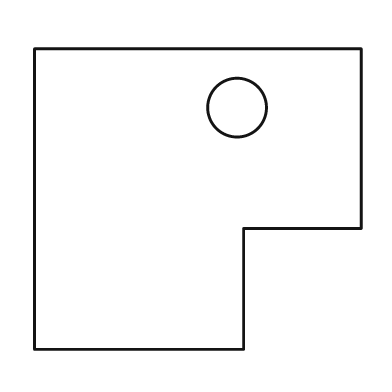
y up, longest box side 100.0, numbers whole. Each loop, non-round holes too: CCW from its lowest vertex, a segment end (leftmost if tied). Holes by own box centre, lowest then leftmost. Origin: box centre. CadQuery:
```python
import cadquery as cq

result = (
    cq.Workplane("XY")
    .moveTo(-50.0, -46.0)
    .lineTo(14.0, -46.0)
    .lineTo(14.0, -9.0)
    .lineTo(50.0, -9.0)
    .lineTo(50.0, 46.0)
    .lineTo(-50.0, 46.0)
    .close()
    .moveTo(12.0, 28.0)
    .circle(9.0)
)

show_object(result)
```